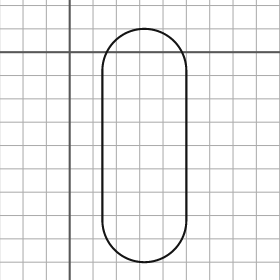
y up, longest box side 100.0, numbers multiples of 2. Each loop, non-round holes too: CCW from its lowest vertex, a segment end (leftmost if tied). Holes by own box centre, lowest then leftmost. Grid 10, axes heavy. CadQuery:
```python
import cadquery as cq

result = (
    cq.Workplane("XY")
    .moveTo(14.0, -72.0)
    .threePointArc((32.0, -90.0), (50.0, -72.0))
    .lineTo(50.0, -8.0)
    .threePointArc((32.0, 10.0), (14.0, -8.0))
    .close()
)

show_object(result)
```